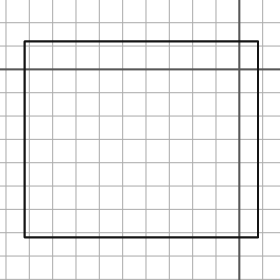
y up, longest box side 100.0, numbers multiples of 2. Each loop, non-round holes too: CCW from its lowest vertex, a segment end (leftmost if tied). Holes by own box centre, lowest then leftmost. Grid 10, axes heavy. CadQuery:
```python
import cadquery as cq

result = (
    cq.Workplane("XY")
    .moveTo(-92.0, -72.0)
    .lineTo(8.0, -72.0)
    .lineTo(8.0, 12.0)
    .lineTo(-92.0, 12.0)
    .close()
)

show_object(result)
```